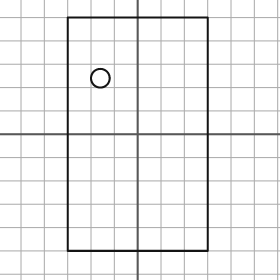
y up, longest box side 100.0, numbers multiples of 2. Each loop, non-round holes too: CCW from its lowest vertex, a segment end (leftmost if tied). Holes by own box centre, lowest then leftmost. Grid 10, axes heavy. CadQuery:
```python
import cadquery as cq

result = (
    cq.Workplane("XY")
    .moveTo(-30.0, -50.0)
    .lineTo(30.0, -50.0)
    .lineTo(30.0, 50.0)
    .lineTo(-30.0, 50.0)
    .close()
    .moveTo(-16.0, 24.0)
    .circle(4.0)
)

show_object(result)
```